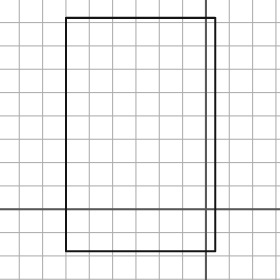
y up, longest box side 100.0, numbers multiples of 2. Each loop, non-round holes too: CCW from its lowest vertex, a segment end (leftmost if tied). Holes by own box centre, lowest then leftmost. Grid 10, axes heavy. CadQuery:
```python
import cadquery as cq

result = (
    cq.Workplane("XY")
    .moveTo(-60.0, -18.0)
    .lineTo(4.0, -18.0)
    .lineTo(4.0, 82.0)
    .lineTo(-60.0, 82.0)
    .close()
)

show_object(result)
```